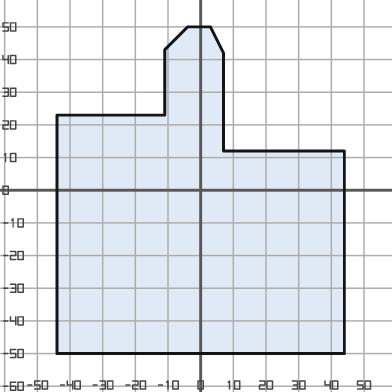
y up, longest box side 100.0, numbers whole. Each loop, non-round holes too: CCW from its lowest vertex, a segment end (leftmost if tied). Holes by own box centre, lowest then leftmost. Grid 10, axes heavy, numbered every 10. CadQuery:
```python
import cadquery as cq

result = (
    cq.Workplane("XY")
    .moveTo(-44.0, -50.0)
    .lineTo(44.0, -50.0)
    .lineTo(44.0, 12.0)
    .lineTo(7.0, 12.0)
    .lineTo(7.0, 42.0)
    .lineTo(3.0, 50.0)
    .lineTo(-4.0, 50.0)
    .lineTo(-11.0, 43.0)
    .lineTo(-11.0, 23.0)
    .lineTo(-44.0, 23.0)
    .close()
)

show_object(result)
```